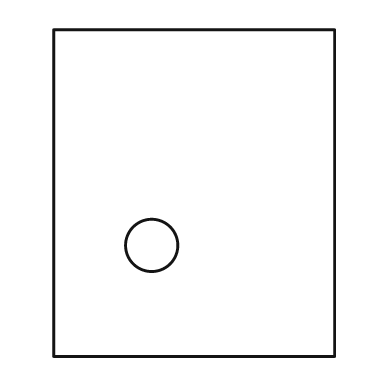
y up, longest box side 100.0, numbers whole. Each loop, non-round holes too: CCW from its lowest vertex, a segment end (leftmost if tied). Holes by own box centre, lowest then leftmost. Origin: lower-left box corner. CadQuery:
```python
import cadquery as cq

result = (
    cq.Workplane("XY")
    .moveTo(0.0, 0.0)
    .lineTo(86.0, 0.0)
    .lineTo(86.0, 100.0)
    .lineTo(0.0, 100.0)
    .close()
    .moveTo(30.0, 34.0)
    .circle(8.0)
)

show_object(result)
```